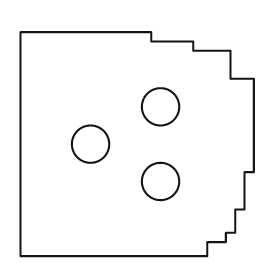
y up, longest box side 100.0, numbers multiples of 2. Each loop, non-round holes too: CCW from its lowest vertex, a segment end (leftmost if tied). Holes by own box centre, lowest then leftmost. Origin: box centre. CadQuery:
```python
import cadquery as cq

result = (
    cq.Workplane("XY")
    .moveTo(-50.0, -48.0)
    .lineTo(30.0, -48.0)
    .lineTo(30.0, -42.0)
    .lineTo(38.0, -42.0)
    .lineTo(38.0, -38.0)
    .lineTo(42.0, -38.0)
    .lineTo(42.0, -28.0)
    .lineTo(46.0, -28.0)
    .lineTo(46.0, -12.0)
    .lineTo(50.0, -12.0)
    .lineTo(50.0, 28.0)
    .lineTo(40.0, 28.0)
    .lineTo(40.0, 40.0)
    .lineTo(24.0, 40.0)
    .lineTo(24.0, 44.0)
    .lineTo(6.0, 44.0)
    .lineTo(6.0, 48.0)
    .lineTo(-50.0, 48.0)
    .close()
    .moveTo(10.0, -16.0)
    .circle(8.0)
    .moveTo(-20.0, 0.0)
    .circle(8.0)
    .moveTo(10.0, 16.0)
    .circle(8.0)
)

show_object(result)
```